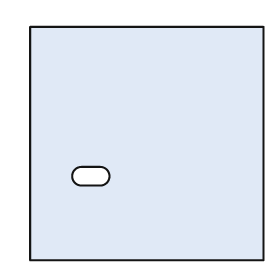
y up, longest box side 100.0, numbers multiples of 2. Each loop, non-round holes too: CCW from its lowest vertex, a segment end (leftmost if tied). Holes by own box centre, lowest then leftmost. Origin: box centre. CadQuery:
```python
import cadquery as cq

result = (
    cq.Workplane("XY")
    .moveTo(-50.0, -50.0)
    .lineTo(50.0, -50.0)
    .lineTo(50.0, 50.0)
    .lineTo(-50.0, 50.0)
    .close()
    .moveTo(-28.0, -18.0)
    .lineTo(-20.0, -18.0)
    .threePointArc((-16.0, -14.0), (-20.0, -10.0))
    .lineTo(-28.0, -10.0)
    .threePointArc((-32.0, -14.0), (-28.0, -18.0))
    .close()
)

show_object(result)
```